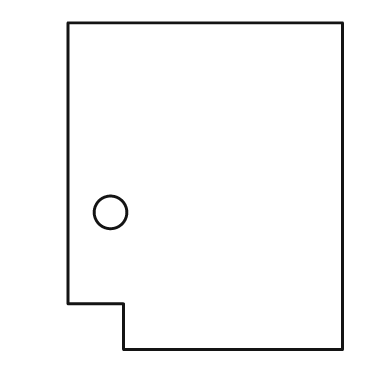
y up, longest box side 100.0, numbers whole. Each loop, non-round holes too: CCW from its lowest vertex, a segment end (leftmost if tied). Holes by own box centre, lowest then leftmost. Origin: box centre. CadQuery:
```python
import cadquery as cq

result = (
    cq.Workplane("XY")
    .moveTo(-25.0, -50.0)
    .lineTo(42.0, -50.0)
    .lineTo(42.0, 50.0)
    .lineTo(-42.0, 50.0)
    .lineTo(-42.0, -36.0)
    .lineTo(-25.0, -36.0)
    .close()
    .moveTo(-29.0, -8.0)
    .circle(5.0)
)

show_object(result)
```